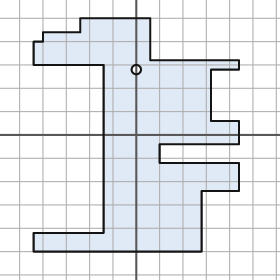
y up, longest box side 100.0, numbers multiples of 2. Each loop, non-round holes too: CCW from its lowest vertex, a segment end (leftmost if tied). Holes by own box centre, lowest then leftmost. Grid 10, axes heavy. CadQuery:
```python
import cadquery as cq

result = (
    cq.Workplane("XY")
    .moveTo(-44.0, -50.0)
    .lineTo(28.0, -50.0)
    .lineTo(28.0, -24.0)
    .lineTo(44.0, -24.0)
    .lineTo(44.0, -12.0)
    .lineTo(10.0, -12.0)
    .lineTo(10.0, -4.0)
    .lineTo(44.0, -4.0)
    .lineTo(44.0, 6.0)
    .lineTo(32.0, 6.0)
    .lineTo(32.0, 28.0)
    .lineTo(44.0, 28.0)
    .lineTo(44.0, 32.0)
    .lineTo(6.0, 32.0)
    .lineTo(6.0, 50.0)
    .lineTo(-24.0, 50.0)
    .lineTo(-24.0, 44.0)
    .lineTo(-40.0, 44.0)
    .lineTo(-40.0, 40.0)
    .lineTo(-44.0, 40.0)
    .lineTo(-44.0, 30.0)
    .lineTo(-14.0, 30.0)
    .lineTo(-14.0, -42.0)
    .lineTo(-44.0, -42.0)
    .close()
    .moveTo(0.0, 28.0)
    .circle(2.0)
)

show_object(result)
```